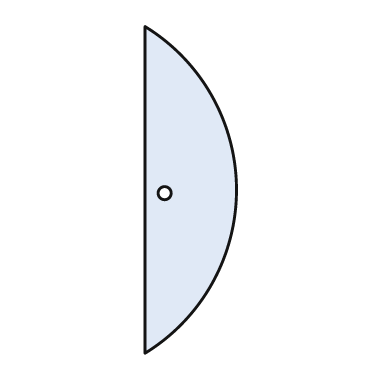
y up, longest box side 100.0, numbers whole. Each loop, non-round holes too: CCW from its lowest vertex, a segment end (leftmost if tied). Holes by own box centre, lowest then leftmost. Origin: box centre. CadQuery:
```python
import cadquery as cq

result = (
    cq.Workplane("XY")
    .moveTo(-14.0, -50.0)
    .threePointArc((14.0, 0.0), (-14.0, 50.0))
    .close()
    .moveTo(-8.0, -1.0)
    .circle(2.0)
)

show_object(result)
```